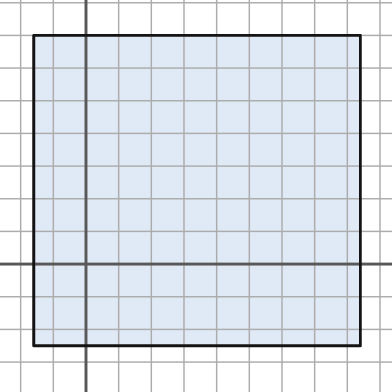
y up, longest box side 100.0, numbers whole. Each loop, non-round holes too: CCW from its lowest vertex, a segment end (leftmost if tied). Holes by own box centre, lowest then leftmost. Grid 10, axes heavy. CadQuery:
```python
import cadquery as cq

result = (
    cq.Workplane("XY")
    .moveTo(-16.0, -25.0)
    .lineTo(84.0, -25.0)
    .lineTo(84.0, 70.0)
    .lineTo(-16.0, 70.0)
    .close()
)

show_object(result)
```